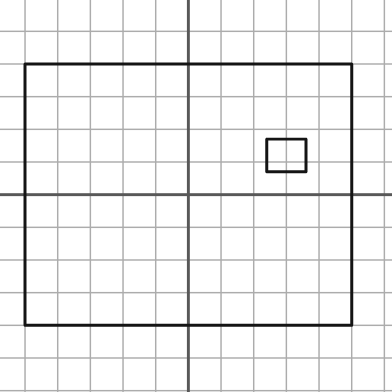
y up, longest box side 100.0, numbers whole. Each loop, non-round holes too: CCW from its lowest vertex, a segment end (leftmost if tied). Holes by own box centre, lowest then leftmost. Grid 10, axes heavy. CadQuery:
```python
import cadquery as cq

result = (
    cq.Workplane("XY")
    .moveTo(-50.0, -40.0)
    .lineTo(50.0, -40.0)
    .lineTo(50.0, 40.0)
    .lineTo(-50.0, 40.0)
    .close()
    .moveTo(24.0, 7.0)
    .lineTo(36.0, 7.0)
    .lineTo(36.0, 17.0)
    .lineTo(24.0, 17.0)
    .close()
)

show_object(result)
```